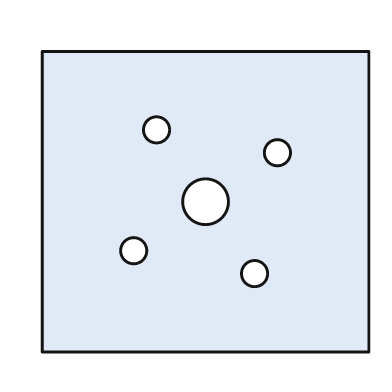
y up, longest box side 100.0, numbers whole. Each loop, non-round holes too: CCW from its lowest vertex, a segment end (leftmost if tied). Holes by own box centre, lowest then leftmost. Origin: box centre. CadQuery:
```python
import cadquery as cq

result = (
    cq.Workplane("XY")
    .moveTo(-50.0, -46.0)
    .lineTo(50.0, -46.0)
    .lineTo(50.0, 46.0)
    .lineTo(-50.0, 46.0)
    .close()
    .moveTo(15.0, -22.0)
    .circle(4.0)
    .moveTo(-22.0, -15.0)
    .circle(4.0)
    .moveTo(0.0, 0.0)
    .circle(7.0)
    .moveTo(22.0, 15.0)
    .circle(4.0)
    .moveTo(-15.0, 22.0)
    .circle(4.0)
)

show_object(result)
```